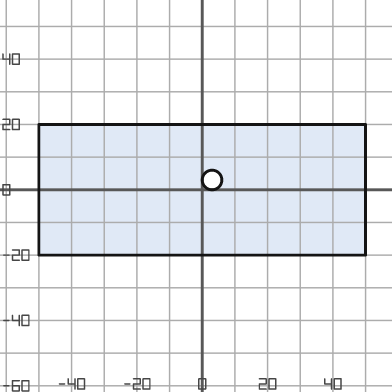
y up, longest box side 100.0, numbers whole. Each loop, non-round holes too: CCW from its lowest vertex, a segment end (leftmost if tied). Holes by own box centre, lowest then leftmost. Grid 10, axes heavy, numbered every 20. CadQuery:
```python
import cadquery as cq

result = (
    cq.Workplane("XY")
    .moveTo(-50.0, -20.0)
    .lineTo(50.0, -20.0)
    .lineTo(50.0, 20.0)
    .lineTo(-50.0, 20.0)
    .close()
    .moveTo(3.0, 3.0)
    .circle(3.0)
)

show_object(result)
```